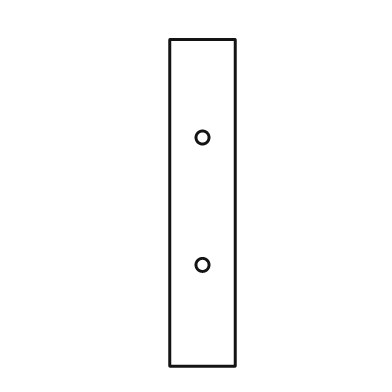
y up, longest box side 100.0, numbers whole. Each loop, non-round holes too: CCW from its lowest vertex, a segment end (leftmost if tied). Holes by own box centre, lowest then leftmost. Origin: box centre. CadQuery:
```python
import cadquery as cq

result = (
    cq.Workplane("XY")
    .moveTo(-10.0, -50.0)
    .lineTo(10.0, -50.0)
    .lineTo(10.0, 50.0)
    .lineTo(-10.0, 50.0)
    .close()
    .moveTo(0.0, -19.0)
    .circle(2.0)
    .moveTo(0.0, 20.0)
    .circle(2.0)
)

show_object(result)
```